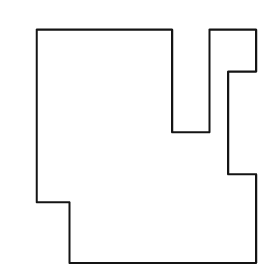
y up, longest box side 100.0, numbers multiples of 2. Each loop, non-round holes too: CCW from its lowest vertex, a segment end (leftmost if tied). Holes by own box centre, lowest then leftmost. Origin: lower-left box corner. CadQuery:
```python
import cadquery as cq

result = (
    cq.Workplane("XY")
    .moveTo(14.0, 0.0)
    .lineTo(94.0, 0.0)
    .lineTo(94.0, 38.0)
    .lineTo(82.0, 38.0)
    .lineTo(82.0, 82.0)
    .lineTo(94.0, 82.0)
    .lineTo(94.0, 100.0)
    .lineTo(74.0, 100.0)
    .lineTo(74.0, 56.0)
    .lineTo(58.0, 56.0)
    .lineTo(58.0, 100.0)
    .lineTo(0.0, 100.0)
    .lineTo(0.0, 26.0)
    .lineTo(14.0, 26.0)
    .close()
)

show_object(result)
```